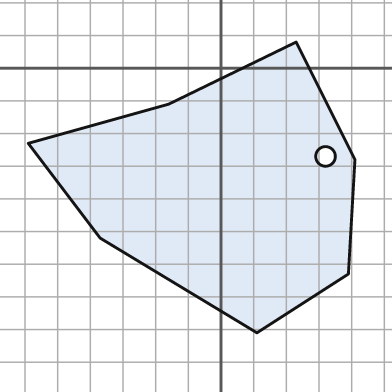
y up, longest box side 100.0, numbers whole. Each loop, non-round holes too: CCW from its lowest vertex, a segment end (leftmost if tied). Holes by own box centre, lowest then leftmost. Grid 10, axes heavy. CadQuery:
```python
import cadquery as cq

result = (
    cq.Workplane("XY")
    .moveTo(11.0, -81.0)
    .lineTo(39.0, -63.0)
    .lineTo(41.0, -28.0)
    .lineTo(23.0, 8.0)
    .lineTo(-16.0, -11.0)
    .lineTo(-59.0, -23.0)
    .lineTo(-37.0, -52.0)
    .close()
    .moveTo(32.0, -27.0)
    .circle(3.0)
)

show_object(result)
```